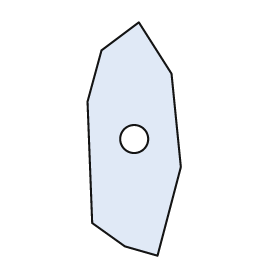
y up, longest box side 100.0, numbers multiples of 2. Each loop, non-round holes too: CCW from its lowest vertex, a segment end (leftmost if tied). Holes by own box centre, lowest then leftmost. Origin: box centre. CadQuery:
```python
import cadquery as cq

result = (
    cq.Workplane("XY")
    .moveTo(10.0, -50.0)
    .lineTo(20.0, -12.0)
    .lineTo(16.0, 28.0)
    .lineTo(2.0, 50.0)
    .lineTo(-14.0, 38.0)
    .lineTo(-20.0, 16.0)
    .lineTo(-18.0, -36.0)
    .lineTo(-4.0, -46.0)
    .close()
    .moveTo(0.0, 0.0)
    .circle(6.0)
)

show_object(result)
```